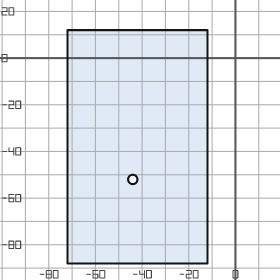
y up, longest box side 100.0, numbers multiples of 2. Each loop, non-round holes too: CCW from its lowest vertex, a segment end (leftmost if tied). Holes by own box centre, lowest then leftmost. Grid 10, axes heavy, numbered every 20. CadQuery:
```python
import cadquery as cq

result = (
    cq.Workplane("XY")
    .moveTo(-72.0, -88.0)
    .lineTo(-12.0, -88.0)
    .lineTo(-12.0, 12.0)
    .lineTo(-72.0, 12.0)
    .close()
    .moveTo(-44.0, -52.0)
    .circle(2.0)
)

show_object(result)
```